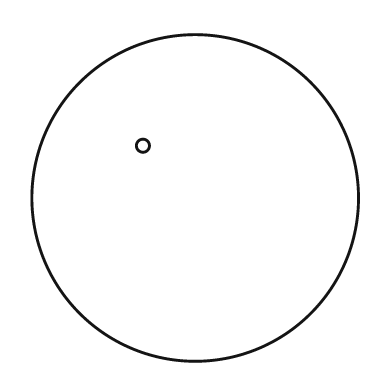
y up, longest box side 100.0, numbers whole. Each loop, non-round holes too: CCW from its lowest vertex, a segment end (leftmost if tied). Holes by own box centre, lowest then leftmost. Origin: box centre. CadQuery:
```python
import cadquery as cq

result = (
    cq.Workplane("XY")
    .moveTo(0.0, 0.0)
    .circle(50.0)
    .moveTo(-16.0, 16.0)
    .circle(2.0)
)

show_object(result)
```